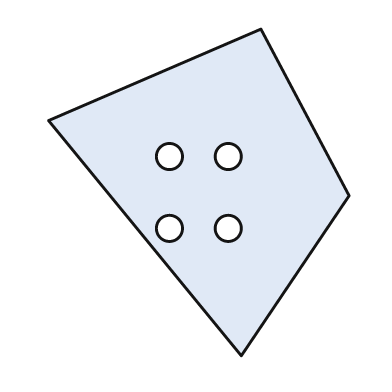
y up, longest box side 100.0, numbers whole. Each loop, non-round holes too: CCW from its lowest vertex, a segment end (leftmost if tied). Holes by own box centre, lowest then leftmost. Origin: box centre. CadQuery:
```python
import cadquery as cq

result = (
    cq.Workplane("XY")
    .moveTo(13.0, -50.0)
    .lineTo(46.0, -1.0)
    .lineTo(19.0, 50.0)
    .lineTo(-46.0, 22.0)
    .close()
    .moveTo(-9.0, -11.0)
    .circle(4.0)
    .moveTo(9.0, -11.0)
    .circle(4.0)
    .moveTo(-9.0, 11.0)
    .circle(4.0)
    .moveTo(9.0, 11.0)
    .circle(4.0)
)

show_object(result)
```